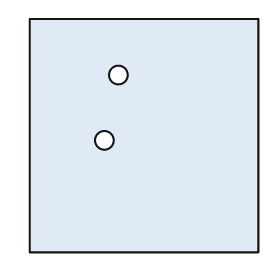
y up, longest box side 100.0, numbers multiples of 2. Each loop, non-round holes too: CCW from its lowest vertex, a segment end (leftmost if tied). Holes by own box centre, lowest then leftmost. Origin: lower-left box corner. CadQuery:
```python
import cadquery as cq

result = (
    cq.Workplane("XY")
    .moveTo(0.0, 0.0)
    .lineTo(98.0, 0.0)
    .lineTo(98.0, 100.0)
    .lineTo(0.0, 100.0)
    .close()
    .moveTo(32.0, 48.0)
    .circle(4.0)
    .moveTo(38.0, 76.0)
    .circle(4.0)
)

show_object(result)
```